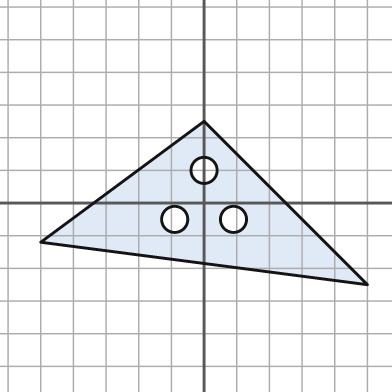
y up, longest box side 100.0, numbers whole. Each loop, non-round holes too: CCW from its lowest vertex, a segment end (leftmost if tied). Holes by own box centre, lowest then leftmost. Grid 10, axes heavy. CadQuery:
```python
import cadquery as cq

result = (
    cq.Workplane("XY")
    .moveTo(50.0, -25.0)
    .lineTo(0.0, 25.0)
    .lineTo(-50.0, -12.0)
    .close()
    .moveTo(-9.0, -5.0)
    .circle(4.0)
    .moveTo(9.0, -5.0)
    .circle(4.0)
    .moveTo(0.0, 10.0)
    .circle(4.0)
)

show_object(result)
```